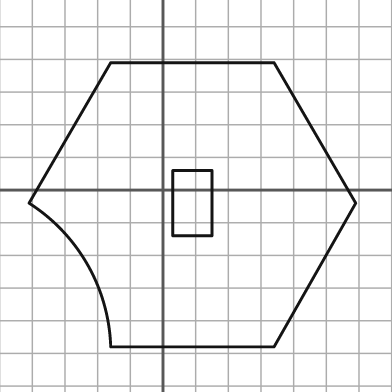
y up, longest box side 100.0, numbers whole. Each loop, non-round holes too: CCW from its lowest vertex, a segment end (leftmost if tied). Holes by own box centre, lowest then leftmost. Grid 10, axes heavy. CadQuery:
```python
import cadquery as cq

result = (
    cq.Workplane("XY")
    .moveTo(-16.0, -48.0)
    .lineTo(34.0, -48.0)
    .lineTo(59.0, -4.0)
    .lineTo(34.0, 39.0)
    .lineTo(-16.0, 39.0)
    .lineTo(-41.0, -4.0)
    .threePointArc((-23.0, -23.0), (-16.0, -48.0))
    .close()
    .moveTo(3.0, -14.0)
    .lineTo(15.0, -14.0)
    .lineTo(15.0, 6.0)
    .lineTo(3.0, 6.0)
    .close()
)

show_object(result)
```